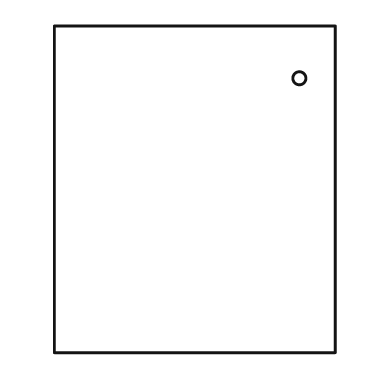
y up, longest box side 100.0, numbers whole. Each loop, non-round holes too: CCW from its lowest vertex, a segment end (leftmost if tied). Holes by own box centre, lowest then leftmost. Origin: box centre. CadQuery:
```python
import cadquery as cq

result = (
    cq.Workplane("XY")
    .moveTo(-43.0, -50.0)
    .lineTo(43.0, -50.0)
    .lineTo(43.0, 50.0)
    .lineTo(-43.0, 50.0)
    .close()
    .moveTo(32.0, 34.0)
    .circle(2.0)
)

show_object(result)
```